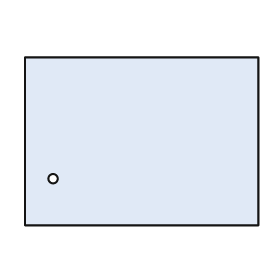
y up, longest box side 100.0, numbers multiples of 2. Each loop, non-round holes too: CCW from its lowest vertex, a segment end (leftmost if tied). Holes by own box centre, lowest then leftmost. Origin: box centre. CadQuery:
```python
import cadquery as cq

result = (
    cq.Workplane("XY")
    .moveTo(-50.0, -36.0)
    .lineTo(50.0, -36.0)
    .lineTo(50.0, 36.0)
    .lineTo(-50.0, 36.0)
    .close()
    .moveTo(-38.0, -16.0)
    .circle(2.0)
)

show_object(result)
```